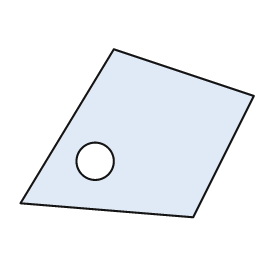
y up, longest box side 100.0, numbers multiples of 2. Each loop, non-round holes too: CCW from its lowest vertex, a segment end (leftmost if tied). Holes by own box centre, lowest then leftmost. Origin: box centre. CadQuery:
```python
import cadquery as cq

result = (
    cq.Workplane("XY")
    .moveTo(24.0, -36.0)
    .lineTo(50.0, 16.0)
    .lineTo(-10.0, 36.0)
    .lineTo(-50.0, -30.0)
    .close()
    .moveTo(-18.0, -12.0)
    .circle(8.0)
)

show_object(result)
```